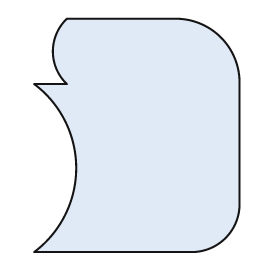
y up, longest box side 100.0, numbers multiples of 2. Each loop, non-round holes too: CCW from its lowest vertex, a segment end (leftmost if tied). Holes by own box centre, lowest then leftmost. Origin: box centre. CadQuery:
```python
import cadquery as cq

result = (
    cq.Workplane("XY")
    .moveTo(-44.0, -50.0)
    .lineTo(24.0, -50.0)
    .threePointArc((38.0, -44.0), (44.0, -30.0))
    .lineTo(44.0, 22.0)
    .threePointArc((36.0, 42.0), (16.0, 50.0))
    .lineTo(-30.0, 50.0)
    .threePointArc((-36.0, 36.0), (-30.0, 22.0))
    .lineTo(-44.0, 22.0)
    .threePointArc((-26.0, -14.0), (-44.0, -50.0))
    .close()
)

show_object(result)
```